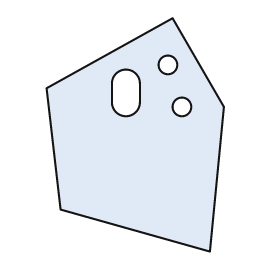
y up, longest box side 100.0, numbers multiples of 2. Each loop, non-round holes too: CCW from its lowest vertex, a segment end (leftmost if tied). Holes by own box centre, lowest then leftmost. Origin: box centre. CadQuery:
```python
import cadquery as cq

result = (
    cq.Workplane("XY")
    .moveTo(32.0, -50.0)
    .lineTo(38.0, 12.0)
    .lineTo(16.0, 50.0)
    .lineTo(-38.0, 20.0)
    .lineTo(-32.0, -32.0)
    .close()
    .moveTo(20.0, 12.0)
    .circle(4.0)
    .moveTo(-10.0, 14.0)
    .threePointArc((-4.0, 8.0), (2.0, 14.0))
    .lineTo(2.0, 22.0)
    .threePointArc((-4.0, 28.0), (-10.0, 22.0))
    .close()
    .moveTo(14.0, 30.0)
    .circle(4.0)
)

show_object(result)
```